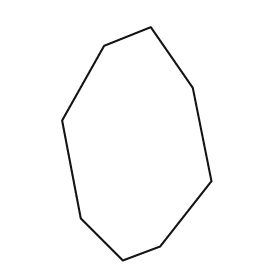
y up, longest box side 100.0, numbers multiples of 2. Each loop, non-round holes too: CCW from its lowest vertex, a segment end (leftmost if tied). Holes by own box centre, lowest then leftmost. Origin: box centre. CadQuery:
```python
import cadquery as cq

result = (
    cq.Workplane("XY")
    .moveTo(-6.0, -50.0)
    .lineTo(10.0, -44.0)
    .lineTo(32.0, -16.0)
    .lineTo(24.0, 24.0)
    .lineTo(6.0, 50.0)
    .lineTo(-14.0, 42.0)
    .lineTo(-32.0, 10.0)
    .lineTo(-24.0, -32.0)
    .close()
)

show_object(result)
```